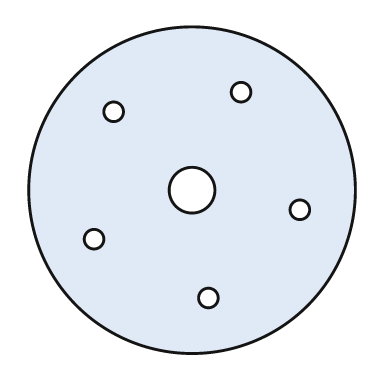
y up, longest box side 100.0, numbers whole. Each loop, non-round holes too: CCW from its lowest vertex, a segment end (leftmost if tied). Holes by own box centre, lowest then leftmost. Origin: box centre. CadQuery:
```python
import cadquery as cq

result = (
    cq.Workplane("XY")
    .moveTo(0.0, 0.0)
    .circle(50.0)
    .moveTo(5.0, -33.0)
    .circle(3.0)
    .moveTo(-30.0, -15.0)
    .circle(3.0)
    .moveTo(33.0, -6.0)
    .circle(3.0)
    .moveTo(0.0, 0.0)
    .circle(7.0)
    .moveTo(-24.0, 24.0)
    .circle(3.0)
    .moveTo(15.0, 30.0)
    .circle(3.0)
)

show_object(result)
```